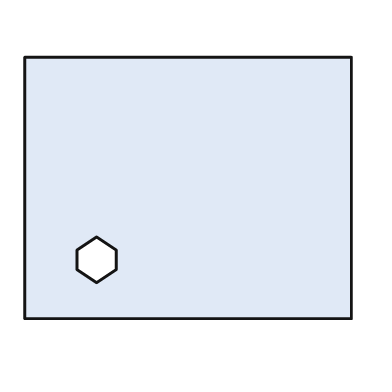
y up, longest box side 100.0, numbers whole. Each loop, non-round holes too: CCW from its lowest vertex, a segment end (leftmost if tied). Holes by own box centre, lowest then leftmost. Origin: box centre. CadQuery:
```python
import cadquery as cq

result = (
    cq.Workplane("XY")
    .moveTo(-50.0, -40.0)
    .lineTo(50.0, -40.0)
    .lineTo(50.0, 40.0)
    .lineTo(-50.0, 40.0)
    .close()
    .moveTo(-28.0, -29.0)
    .lineTo(-22.0, -25.0)
    .lineTo(-22.0, -19.0)
    .lineTo(-28.0, -15.0)
    .lineTo(-34.0, -19.0)
    .lineTo(-34.0, -25.0)
    .close()
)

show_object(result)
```